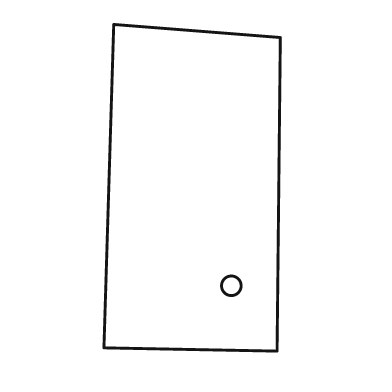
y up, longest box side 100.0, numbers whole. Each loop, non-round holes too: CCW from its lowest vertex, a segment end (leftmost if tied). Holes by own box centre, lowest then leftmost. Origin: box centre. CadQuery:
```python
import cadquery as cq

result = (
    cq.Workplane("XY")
    .moveTo(26.0, -50.0)
    .lineTo(27.0, 46.0)
    .lineTo(-24.0, 50.0)
    .lineTo(-27.0, -49.0)
    .close()
    .moveTo(12.0, -30.0)
    .circle(3.0)
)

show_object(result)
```